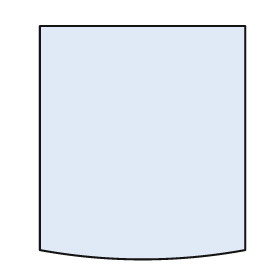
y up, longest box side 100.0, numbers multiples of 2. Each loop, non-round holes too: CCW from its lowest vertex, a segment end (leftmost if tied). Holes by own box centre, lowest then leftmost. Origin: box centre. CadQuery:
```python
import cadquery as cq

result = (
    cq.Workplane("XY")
    .moveTo(-44.0, -46.0)
    .threePointArc((0.0, -50.0), (44.0, -46.0))
    .lineTo(44.0, 50.0)
    .lineTo(-44.0, 50.0)
    .close()
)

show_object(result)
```